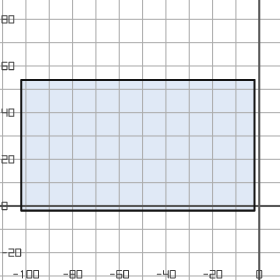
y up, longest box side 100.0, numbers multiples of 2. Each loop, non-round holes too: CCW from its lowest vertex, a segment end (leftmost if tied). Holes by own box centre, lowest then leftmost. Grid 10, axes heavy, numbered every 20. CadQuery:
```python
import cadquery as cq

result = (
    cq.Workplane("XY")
    .moveTo(-102.0, -2.0)
    .lineTo(-2.0, -2.0)
    .lineTo(-2.0, 54.0)
    .lineTo(-102.0, 54.0)
    .close()
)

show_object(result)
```